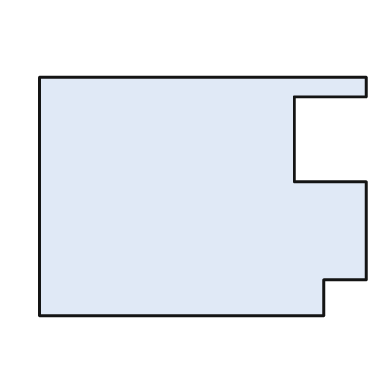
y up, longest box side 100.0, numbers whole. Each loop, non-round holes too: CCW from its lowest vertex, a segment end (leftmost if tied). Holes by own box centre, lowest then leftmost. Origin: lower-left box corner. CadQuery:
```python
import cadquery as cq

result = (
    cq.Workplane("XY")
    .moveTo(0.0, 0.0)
    .lineTo(87.0, 0.0)
    .lineTo(87.0, 11.0)
    .lineTo(100.0, 11.0)
    .lineTo(100.0, 41.0)
    .lineTo(78.0, 41.0)
    .lineTo(78.0, 67.0)
    .lineTo(100.0, 67.0)
    .lineTo(100.0, 73.0)
    .lineTo(0.0, 73.0)
    .close()
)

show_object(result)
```